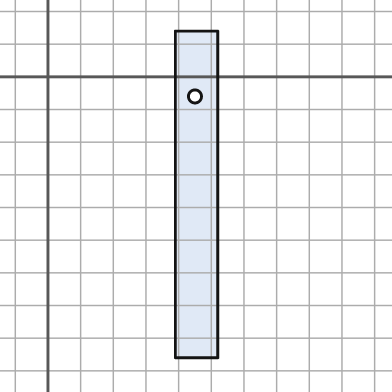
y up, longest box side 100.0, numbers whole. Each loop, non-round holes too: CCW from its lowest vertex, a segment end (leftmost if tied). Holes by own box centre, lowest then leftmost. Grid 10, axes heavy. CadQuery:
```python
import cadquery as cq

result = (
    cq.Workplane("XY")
    .moveTo(39.0, -86.0)
    .lineTo(52.0, -86.0)
    .lineTo(52.0, 14.0)
    .lineTo(39.0, 14.0)
    .close()
    .moveTo(45.0, -6.0)
    .circle(2.0)
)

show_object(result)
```